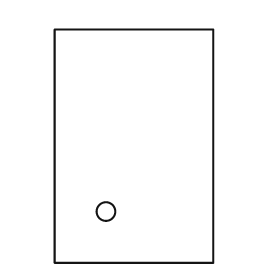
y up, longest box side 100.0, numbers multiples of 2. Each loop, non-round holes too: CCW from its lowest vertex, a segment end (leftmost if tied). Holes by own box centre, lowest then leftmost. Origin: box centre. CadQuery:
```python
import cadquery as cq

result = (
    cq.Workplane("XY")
    .moveTo(-34.0, -50.0)
    .lineTo(34.0, -50.0)
    .lineTo(34.0, 50.0)
    .lineTo(-34.0, 50.0)
    .close()
    .moveTo(-12.0, -28.0)
    .circle(4.0)
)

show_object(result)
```